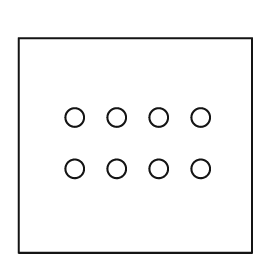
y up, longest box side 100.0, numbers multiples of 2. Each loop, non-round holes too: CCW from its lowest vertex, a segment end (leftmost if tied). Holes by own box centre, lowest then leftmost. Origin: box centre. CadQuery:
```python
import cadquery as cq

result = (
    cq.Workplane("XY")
    .moveTo(-50.0, -46.0)
    .lineTo(50.0, -46.0)
    .lineTo(50.0, 46.0)
    .lineTo(-50.0, 46.0)
    .close()
    .moveTo(-26.0, -10.0)
    .circle(4.0)
    .moveTo(-8.0, -10.0)
    .circle(4.0)
    .moveTo(10.0, -10.0)
    .circle(4.0)
    .moveTo(28.0, -10.0)
    .circle(4.0)
    .moveTo(-26.0, 12.0)
    .circle(4.0)
    .moveTo(-8.0, 12.0)
    .circle(4.0)
    .moveTo(10.0, 12.0)
    .circle(4.0)
    .moveTo(28.0, 12.0)
    .circle(4.0)
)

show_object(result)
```